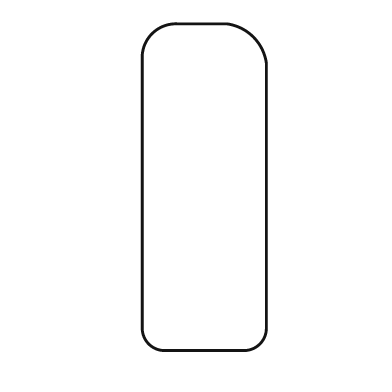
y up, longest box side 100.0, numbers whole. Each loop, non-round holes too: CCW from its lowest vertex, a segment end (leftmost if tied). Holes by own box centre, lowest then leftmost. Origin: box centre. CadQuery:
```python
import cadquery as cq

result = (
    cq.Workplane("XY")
    .moveTo(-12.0, -50.0)
    .lineTo(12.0, -50.0)
    .threePointArc((17.0, -48.0), (19.0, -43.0))
    .lineTo(19.0, 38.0)
    .threePointArc((15.0, 46.0), (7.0, 50.0))
    .lineTo(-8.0, 50.0)
    .threePointArc((-16.0, 47.0), (-19.0, 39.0))
    .lineTo(-19.0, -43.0)
    .threePointArc((-17.0, -48.0), (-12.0, -50.0))
    .close()
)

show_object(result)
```